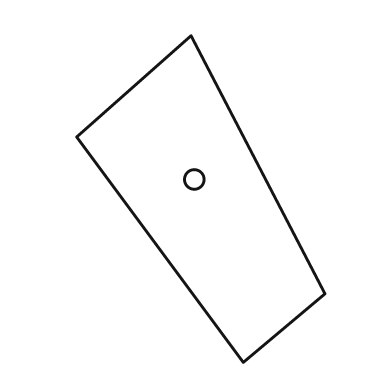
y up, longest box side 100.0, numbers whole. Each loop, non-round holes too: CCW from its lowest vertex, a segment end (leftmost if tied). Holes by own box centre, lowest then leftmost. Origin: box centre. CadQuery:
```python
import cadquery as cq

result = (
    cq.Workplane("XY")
    .moveTo(13.0, -50.0)
    .lineTo(38.0, -29.0)
    .lineTo(-3.0, 50.0)
    .lineTo(-38.0, 19.0)
    .close()
    .moveTo(-2.0, 6.0)
    .circle(3.0)
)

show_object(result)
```